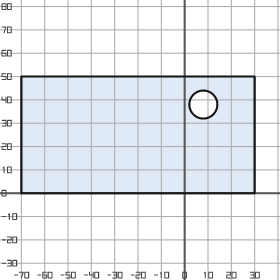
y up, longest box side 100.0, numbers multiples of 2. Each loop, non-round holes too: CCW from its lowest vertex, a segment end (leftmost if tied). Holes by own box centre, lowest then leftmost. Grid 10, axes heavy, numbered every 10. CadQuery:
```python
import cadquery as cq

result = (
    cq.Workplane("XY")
    .moveTo(-70.0, 0.0)
    .lineTo(30.0, 0.0)
    .lineTo(30.0, 50.0)
    .lineTo(-70.0, 50.0)
    .close()
    .moveTo(8.0, 38.0)
    .circle(6.0)
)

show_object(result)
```